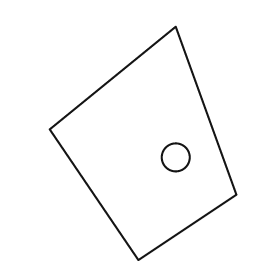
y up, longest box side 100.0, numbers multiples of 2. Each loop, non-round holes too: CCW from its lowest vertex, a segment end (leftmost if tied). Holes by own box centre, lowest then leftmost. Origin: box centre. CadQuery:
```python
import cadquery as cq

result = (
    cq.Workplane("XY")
    .moveTo(-2.0, -50.0)
    .lineTo(40.0, -22.0)
    .lineTo(14.0, 50.0)
    .lineTo(-40.0, 6.0)
    .close()
    .moveTo(14.0, -6.0)
    .circle(6.0)
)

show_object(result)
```